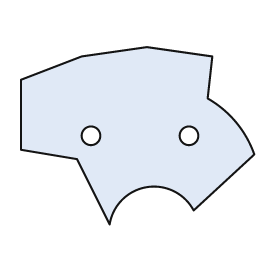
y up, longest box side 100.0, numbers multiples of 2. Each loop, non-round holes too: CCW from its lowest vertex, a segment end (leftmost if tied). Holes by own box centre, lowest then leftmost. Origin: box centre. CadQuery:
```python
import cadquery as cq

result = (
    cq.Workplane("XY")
    .moveTo(-12.0, -38.0)
    .threePointArc((4.0, -22.0), (24.0, -32.0))
    .lineTo(50.0, -8.0)
    .threePointArc((42.0, 6.0), (30.0, 16.0))
    .lineTo(32.0, 34.0)
    .lineTo(4.0, 38.0)
    .lineTo(-24.0, 34.0)
    .lineTo(-50.0, 24.0)
    .lineTo(-50.0, -6.0)
    .lineTo(-26.0, -10.0)
    .close()
    .moveTo(-20.0, 0.0)
    .circle(4.0)
    .moveTo(22.0, 0.0)
    .circle(4.0)
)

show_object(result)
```